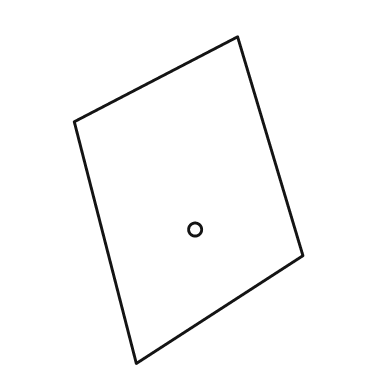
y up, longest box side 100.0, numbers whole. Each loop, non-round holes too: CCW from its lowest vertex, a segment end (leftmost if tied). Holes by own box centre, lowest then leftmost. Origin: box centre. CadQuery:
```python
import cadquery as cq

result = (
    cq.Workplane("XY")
    .moveTo(-16.0, -50.0)
    .lineTo(35.0, -17.0)
    .lineTo(15.0, 50.0)
    .lineTo(-35.0, 24.0)
    .close()
    .moveTo(2.0, -9.0)
    .circle(2.0)
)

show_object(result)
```